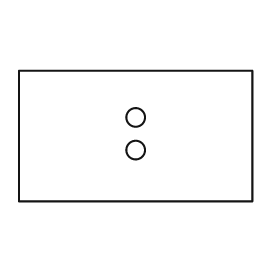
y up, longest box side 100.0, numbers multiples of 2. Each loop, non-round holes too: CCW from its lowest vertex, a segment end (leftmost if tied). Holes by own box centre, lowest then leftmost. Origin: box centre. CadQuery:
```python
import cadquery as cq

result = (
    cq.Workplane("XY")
    .moveTo(-50.0, -28.0)
    .lineTo(50.0, -28.0)
    .lineTo(50.0, 28.0)
    .lineTo(-50.0, 28.0)
    .close()
    .moveTo(0.0, -6.0)
    .circle(4.0)
    .moveTo(0.0, 8.0)
    .circle(4.0)
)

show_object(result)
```